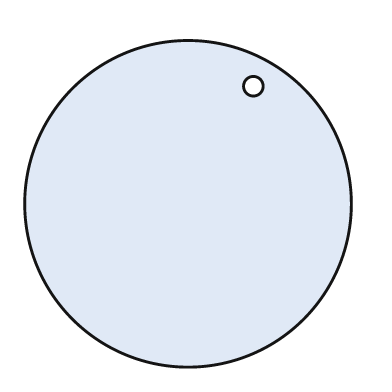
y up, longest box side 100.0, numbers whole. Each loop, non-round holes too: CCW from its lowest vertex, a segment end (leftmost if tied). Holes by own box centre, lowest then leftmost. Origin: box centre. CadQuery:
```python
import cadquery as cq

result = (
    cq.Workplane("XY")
    .moveTo(0.0, 0.0)
    .circle(50.0)
    .moveTo(20.0, 36.0)
    .circle(3.0)
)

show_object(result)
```